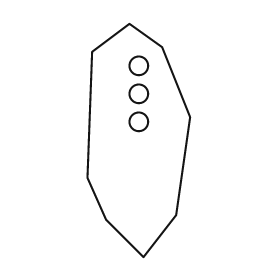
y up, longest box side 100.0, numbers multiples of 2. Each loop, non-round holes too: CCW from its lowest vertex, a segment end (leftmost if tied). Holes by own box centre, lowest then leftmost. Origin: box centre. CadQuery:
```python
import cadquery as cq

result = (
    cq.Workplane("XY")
    .moveTo(2.0, -50.0)
    .lineTo(16.0, -32.0)
    .lineTo(22.0, 10.0)
    .lineTo(10.0, 40.0)
    .lineTo(-4.0, 50.0)
    .lineTo(-20.0, 38.0)
    .lineTo(-22.0, -16.0)
    .lineTo(-14.0, -34.0)
    .close()
    .moveTo(0.0, 8.0)
    .circle(4.0)
    .moveTo(0.0, 20.0)
    .circle(4.0)
    .moveTo(0.0, 32.0)
    .circle(4.0)
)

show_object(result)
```